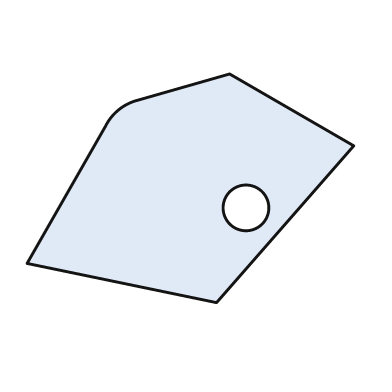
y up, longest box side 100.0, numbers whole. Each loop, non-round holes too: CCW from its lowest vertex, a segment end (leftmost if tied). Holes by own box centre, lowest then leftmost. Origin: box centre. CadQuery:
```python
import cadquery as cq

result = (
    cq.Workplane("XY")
    .moveTo(8.0, -35.0)
    .lineTo(50.0, 13.0)
    .lineTo(12.0, 35.0)
    .lineTo(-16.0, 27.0)
    .threePointArc((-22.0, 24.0), (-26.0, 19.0))
    .lineTo(-50.0, -23.0)
    .close()
    .moveTo(17.0, -6.0)
    .circle(7.0)
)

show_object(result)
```